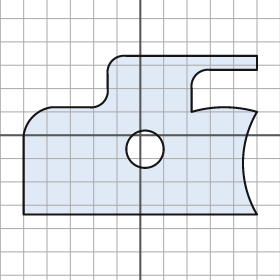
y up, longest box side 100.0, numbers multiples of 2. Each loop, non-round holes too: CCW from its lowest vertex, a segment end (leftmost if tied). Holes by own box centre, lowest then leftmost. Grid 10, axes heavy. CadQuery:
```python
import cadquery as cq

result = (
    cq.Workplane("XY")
    .moveTo(-50.0, -34.0)
    .lineTo(50.0, -34.0)
    .threePointArc((44.0, -12.0), (50.0, 10.0))
    .threePointArc((36.0, 12.0), (22.0, 10.0))
    .lineTo(22.0, 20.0)
    .threePointArc((24.0, 26.0), (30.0, 28.0))
    .lineTo(50.0, 28.0)
    .lineTo(50.0, 34.0)
    .lineTo(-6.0, 34.0)
    .threePointArc((-12.0, 32.0), (-14.0, 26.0))
    .lineTo(-14.0, 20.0)
    .threePointArc((-16.0, 14.0), (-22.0, 12.0))
    .lineTo(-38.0, 12.0)
    .threePointArc((-46.0, 8.0), (-50.0, 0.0))
    .close()
    .moveTo(2.0, -6.0)
    .circle(8.0)
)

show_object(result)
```